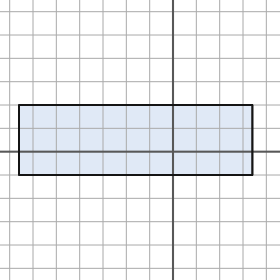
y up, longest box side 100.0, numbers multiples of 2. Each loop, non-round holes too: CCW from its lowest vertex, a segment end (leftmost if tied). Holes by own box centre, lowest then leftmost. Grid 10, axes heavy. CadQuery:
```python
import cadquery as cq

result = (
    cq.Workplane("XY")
    .moveTo(-66.0, -10.0)
    .lineTo(34.0, -10.0)
    .lineTo(34.0, 20.0)
    .lineTo(-66.0, 20.0)
    .close()
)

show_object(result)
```